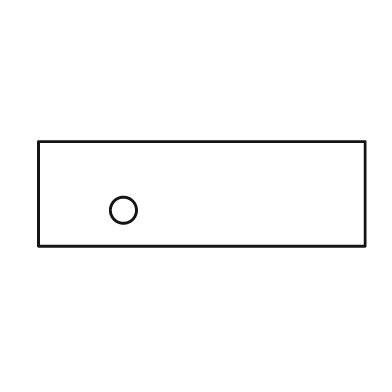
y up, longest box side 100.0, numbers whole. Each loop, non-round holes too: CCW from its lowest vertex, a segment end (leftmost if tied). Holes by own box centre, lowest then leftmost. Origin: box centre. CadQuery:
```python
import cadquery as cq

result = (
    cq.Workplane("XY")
    .moveTo(-50.0, -16.0)
    .lineTo(50.0, -16.0)
    .lineTo(50.0, 16.0)
    .lineTo(-50.0, 16.0)
    .close()
    .moveTo(-24.0, -5.0)
    .circle(4.0)
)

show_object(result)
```